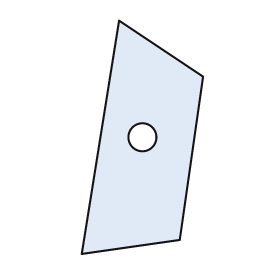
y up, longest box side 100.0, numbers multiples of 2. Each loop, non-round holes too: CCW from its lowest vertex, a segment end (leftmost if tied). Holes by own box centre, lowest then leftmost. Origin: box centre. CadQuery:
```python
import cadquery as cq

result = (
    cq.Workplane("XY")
    .moveTo(-26.0, -50.0)
    .lineTo(16.0, -44.0)
    .lineTo(26.0, 26.0)
    .lineTo(-10.0, 50.0)
    .close()
    .moveTo(0.0, 0.0)
    .circle(6.0)
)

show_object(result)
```